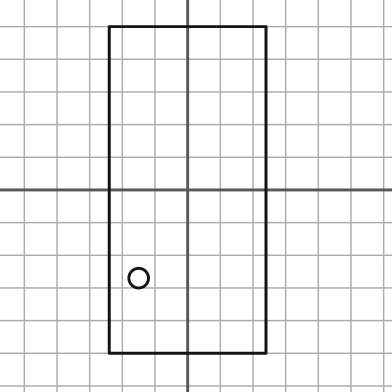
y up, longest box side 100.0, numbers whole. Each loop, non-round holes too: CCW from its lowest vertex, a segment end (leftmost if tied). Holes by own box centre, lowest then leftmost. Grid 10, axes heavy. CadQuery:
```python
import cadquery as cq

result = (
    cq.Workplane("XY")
    .moveTo(-24.0, -50.0)
    .lineTo(24.0, -50.0)
    .lineTo(24.0, 50.0)
    .lineTo(-24.0, 50.0)
    .close()
    .moveTo(-15.0, -27.0)
    .circle(3.0)
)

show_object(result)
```